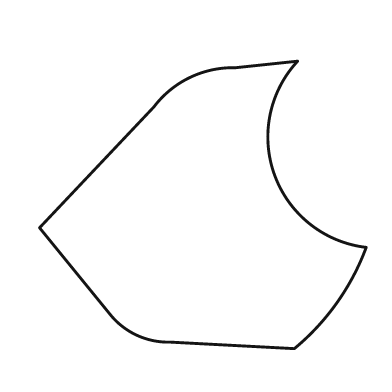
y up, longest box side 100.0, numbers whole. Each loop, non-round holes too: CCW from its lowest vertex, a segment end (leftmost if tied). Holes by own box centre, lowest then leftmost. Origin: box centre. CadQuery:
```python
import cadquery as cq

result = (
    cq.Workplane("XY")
    .moveTo(28.0, -44.0)
    .threePointArc((41.0, -30.0), (50.0, -13.0))
    .threePointArc((22.0, 9.0), (29.0, 44.0))
    .lineTo(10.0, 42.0)
    .threePointArc((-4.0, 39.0), (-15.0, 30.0))
    .lineTo(-50.0, -7.0)
    .lineTo(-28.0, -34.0)
    .threePointArc((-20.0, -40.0), (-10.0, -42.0))
    .close()
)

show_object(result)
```